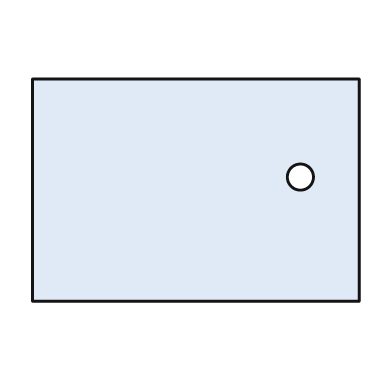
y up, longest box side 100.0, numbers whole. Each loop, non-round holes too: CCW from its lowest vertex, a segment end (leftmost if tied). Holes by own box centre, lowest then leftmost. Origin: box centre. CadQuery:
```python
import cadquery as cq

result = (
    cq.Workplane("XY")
    .moveTo(-50.0, -34.0)
    .lineTo(50.0, -34.0)
    .lineTo(50.0, 34.0)
    .lineTo(-50.0, 34.0)
    .close()
    .moveTo(32.0, 4.0)
    .circle(4.0)
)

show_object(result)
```